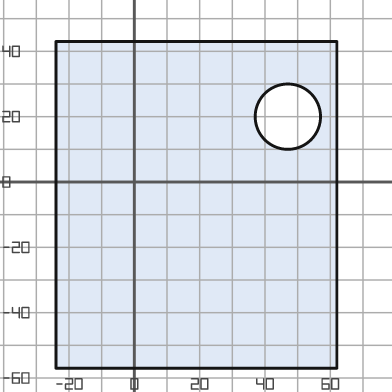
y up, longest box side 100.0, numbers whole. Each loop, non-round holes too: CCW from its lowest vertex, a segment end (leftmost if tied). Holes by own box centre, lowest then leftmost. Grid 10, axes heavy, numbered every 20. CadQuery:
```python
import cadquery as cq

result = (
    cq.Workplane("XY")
    .moveTo(-24.0, -57.0)
    .lineTo(62.0, -57.0)
    .lineTo(62.0, 43.0)
    .lineTo(-24.0, 43.0)
    .close()
    .moveTo(47.0, 20.0)
    .circle(10.0)
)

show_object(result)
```